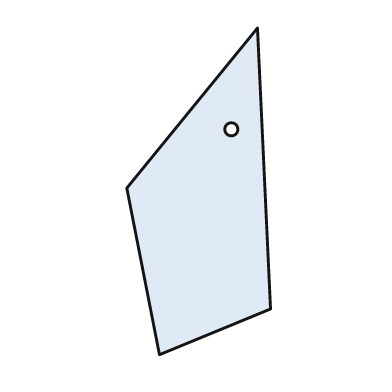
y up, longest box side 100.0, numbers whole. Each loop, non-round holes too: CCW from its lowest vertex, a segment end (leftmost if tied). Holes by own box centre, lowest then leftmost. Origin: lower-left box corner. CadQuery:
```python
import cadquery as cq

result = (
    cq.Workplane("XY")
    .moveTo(10.0, 0.0)
    .lineTo(44.0, 14.0)
    .lineTo(40.0, 100.0)
    .lineTo(0.0, 51.0)
    .close()
    .moveTo(32.0, 69.0)
    .circle(2.0)
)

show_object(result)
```